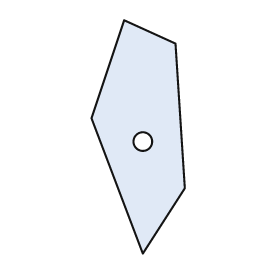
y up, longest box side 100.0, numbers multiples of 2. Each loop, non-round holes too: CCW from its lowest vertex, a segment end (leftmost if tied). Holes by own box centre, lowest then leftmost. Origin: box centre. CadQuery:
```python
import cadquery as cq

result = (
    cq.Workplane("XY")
    .moveTo(2.0, -50.0)
    .lineTo(20.0, -22.0)
    .lineTo(16.0, 40.0)
    .lineTo(-6.0, 50.0)
    .lineTo(-20.0, 8.0)
    .close()
    .moveTo(2.0, -2.0)
    .circle(4.0)
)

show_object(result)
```